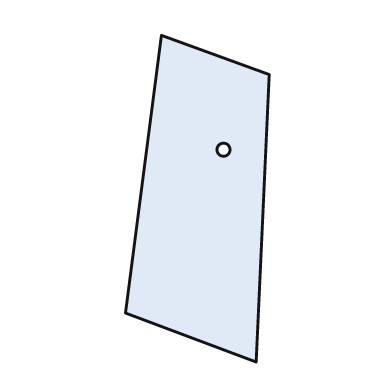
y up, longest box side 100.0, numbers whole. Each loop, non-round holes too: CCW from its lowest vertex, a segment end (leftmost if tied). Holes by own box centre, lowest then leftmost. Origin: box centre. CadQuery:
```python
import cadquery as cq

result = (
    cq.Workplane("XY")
    .moveTo(18.0, -50.0)
    .lineTo(22.0, 38.0)
    .lineTo(-11.0, 50.0)
    .lineTo(-22.0, -35.0)
    .close()
    .moveTo(8.0, 15.0)
    .circle(2.0)
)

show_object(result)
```